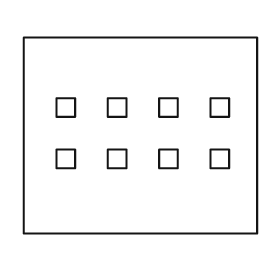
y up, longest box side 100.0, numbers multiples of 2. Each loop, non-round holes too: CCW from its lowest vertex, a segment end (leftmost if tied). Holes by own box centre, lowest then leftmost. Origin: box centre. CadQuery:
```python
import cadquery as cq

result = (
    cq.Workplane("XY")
    .moveTo(-50.0, -42.0)
    .lineTo(50.0, -42.0)
    .lineTo(50.0, 42.0)
    .lineTo(-50.0, 42.0)
    .close()
    .moveTo(-36.0, -14.0)
    .lineTo(-28.0, -14.0)
    .lineTo(-28.0, -6.0)
    .lineTo(-36.0, -6.0)
    .close()
    .moveTo(-14.0, -14.0)
    .lineTo(-6.0, -14.0)
    .lineTo(-6.0, -6.0)
    .lineTo(-14.0, -6.0)
    .close()
    .moveTo(8.0, -14.0)
    .lineTo(16.0, -14.0)
    .lineTo(16.0, -6.0)
    .lineTo(8.0, -6.0)
    .close()
    .moveTo(30.0, -14.0)
    .lineTo(38.0, -14.0)
    .lineTo(38.0, -6.0)
    .lineTo(30.0, -6.0)
    .close()
    .moveTo(-36.0, 8.0)
    .lineTo(-28.0, 8.0)
    .lineTo(-28.0, 16.0)
    .lineTo(-36.0, 16.0)
    .close()
    .moveTo(-14.0, 8.0)
    .lineTo(-6.0, 8.0)
    .lineTo(-6.0, 16.0)
    .lineTo(-14.0, 16.0)
    .close()
    .moveTo(8.0, 8.0)
    .lineTo(16.0, 8.0)
    .lineTo(16.0, 16.0)
    .lineTo(8.0, 16.0)
    .close()
    .moveTo(30.0, 8.0)
    .lineTo(38.0, 8.0)
    .lineTo(38.0, 16.0)
    .lineTo(30.0, 16.0)
    .close()
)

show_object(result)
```